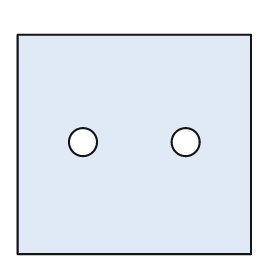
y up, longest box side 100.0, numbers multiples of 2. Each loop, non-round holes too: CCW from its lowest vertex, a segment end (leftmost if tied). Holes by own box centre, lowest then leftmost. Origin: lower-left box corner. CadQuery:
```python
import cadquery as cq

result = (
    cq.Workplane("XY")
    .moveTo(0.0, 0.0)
    .lineTo(100.0, 0.0)
    .lineTo(100.0, 94.0)
    .lineTo(0.0, 94.0)
    .close()
    .moveTo(28.0, 48.0)
    .circle(6.0)
    .moveTo(72.0, 48.0)
    .circle(6.0)
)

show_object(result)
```